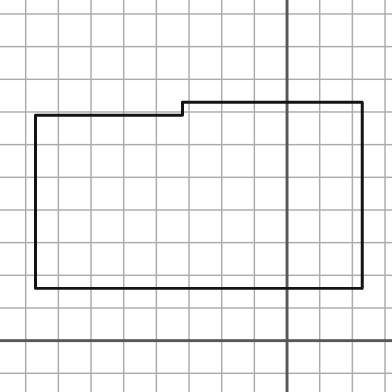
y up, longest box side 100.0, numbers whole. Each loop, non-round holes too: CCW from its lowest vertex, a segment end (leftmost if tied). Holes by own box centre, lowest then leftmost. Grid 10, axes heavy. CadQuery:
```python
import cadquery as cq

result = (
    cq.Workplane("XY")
    .moveTo(-77.0, 16.0)
    .lineTo(23.0, 16.0)
    .lineTo(23.0, 73.0)
    .lineTo(-32.0, 73.0)
    .lineTo(-32.0, 69.0)
    .lineTo(-77.0, 69.0)
    .close()
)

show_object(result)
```